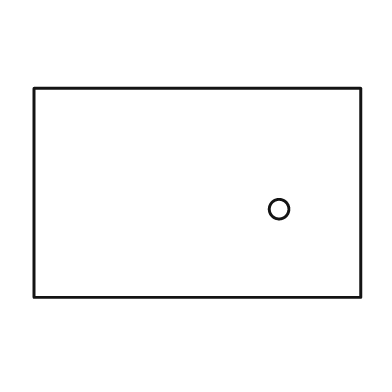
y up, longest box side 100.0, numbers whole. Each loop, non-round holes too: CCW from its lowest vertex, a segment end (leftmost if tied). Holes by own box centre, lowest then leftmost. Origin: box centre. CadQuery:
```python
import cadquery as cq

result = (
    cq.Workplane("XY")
    .moveTo(-50.0, -32.0)
    .lineTo(50.0, -32.0)
    .lineTo(50.0, 32.0)
    .lineTo(-50.0, 32.0)
    .close()
    .moveTo(25.0, -5.0)
    .circle(3.0)
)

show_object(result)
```